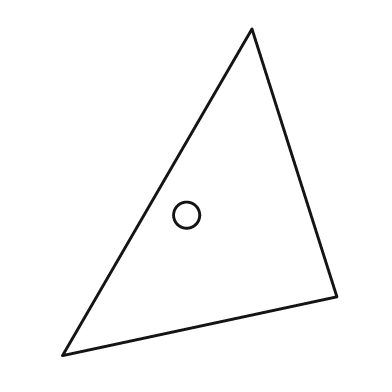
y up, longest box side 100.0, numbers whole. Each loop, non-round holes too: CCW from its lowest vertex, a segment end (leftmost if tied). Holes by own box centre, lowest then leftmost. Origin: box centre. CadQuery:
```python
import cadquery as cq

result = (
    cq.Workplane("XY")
    .moveTo(-42.0, -50.0)
    .lineTo(42.0, -32.0)
    .lineTo(16.0, 50.0)
    .close()
    .moveTo(-4.0, -7.0)
    .circle(4.0)
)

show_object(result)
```